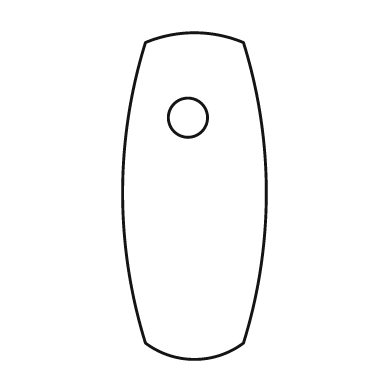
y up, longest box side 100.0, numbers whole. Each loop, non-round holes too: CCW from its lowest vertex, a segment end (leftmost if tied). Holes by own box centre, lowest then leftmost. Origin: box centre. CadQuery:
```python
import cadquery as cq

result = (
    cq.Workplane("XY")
    .moveTo(-15.0, -45.0)
    .threePointArc((0.0, -50.0), (15.0, -45.0))
    .threePointArc((22.0, 1.0), (15.0, 47.0))
    .threePointArc((0.0, 50.0), (-15.0, 47.0))
    .threePointArc((-22.0, 1.0), (-15.0, -45.0))
    .close()
    .moveTo(-2.0, 24.0)
    .circle(6.0)
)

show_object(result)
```